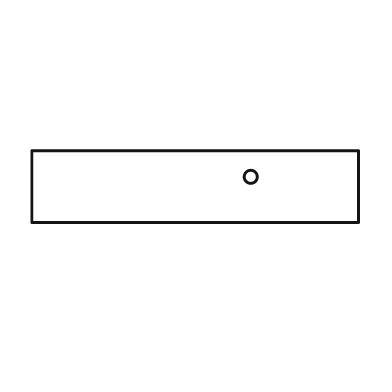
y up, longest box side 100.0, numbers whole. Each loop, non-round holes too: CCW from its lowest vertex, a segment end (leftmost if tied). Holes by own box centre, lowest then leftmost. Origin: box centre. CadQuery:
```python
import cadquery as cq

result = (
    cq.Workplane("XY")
    .moveTo(-50.0, -11.0)
    .lineTo(50.0, -11.0)
    .lineTo(50.0, 11.0)
    .lineTo(-50.0, 11.0)
    .close()
    .moveTo(17.0, 3.0)
    .circle(2.0)
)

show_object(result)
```